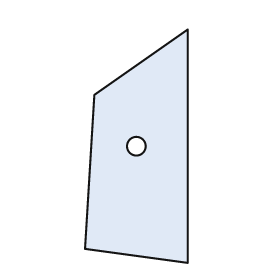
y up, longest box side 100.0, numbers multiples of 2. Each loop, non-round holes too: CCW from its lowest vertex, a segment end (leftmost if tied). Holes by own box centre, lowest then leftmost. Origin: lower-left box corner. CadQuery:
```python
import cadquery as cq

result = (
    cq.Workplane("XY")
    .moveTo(44.0, 0.0)
    .lineTo(44.0, 100.0)
    .lineTo(4.0, 72.0)
    .lineTo(0.0, 6.0)
    .close()
    .moveTo(22.0, 50.0)
    .circle(4.0)
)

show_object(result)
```